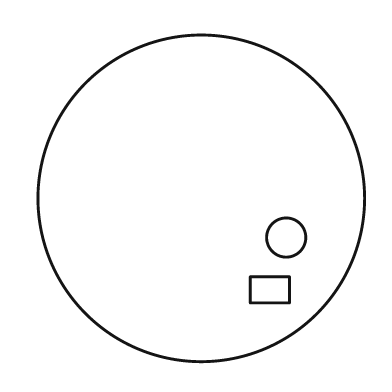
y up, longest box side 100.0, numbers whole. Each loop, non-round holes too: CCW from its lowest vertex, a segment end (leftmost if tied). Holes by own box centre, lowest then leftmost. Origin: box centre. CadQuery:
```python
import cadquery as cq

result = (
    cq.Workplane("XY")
    .moveTo(0.0, 0.0)
    .circle(50.0)
    .moveTo(15.0, -32.0)
    .lineTo(27.0, -32.0)
    .lineTo(27.0, -24.0)
    .lineTo(15.0, -24.0)
    .close()
    .moveTo(26.0, -12.0)
    .circle(6.0)
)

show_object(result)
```